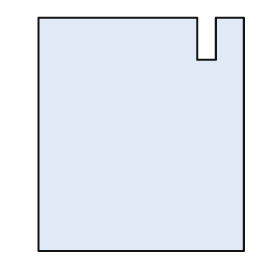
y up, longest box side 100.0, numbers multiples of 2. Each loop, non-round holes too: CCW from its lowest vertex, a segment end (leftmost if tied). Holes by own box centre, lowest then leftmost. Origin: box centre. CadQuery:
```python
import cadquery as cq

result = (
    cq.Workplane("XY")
    .moveTo(-44.0, -50.0)
    .lineTo(44.0, -50.0)
    .lineTo(44.0, 50.0)
    .lineTo(32.0, 50.0)
    .lineTo(32.0, 32.0)
    .lineTo(24.0, 32.0)
    .lineTo(24.0, 50.0)
    .lineTo(-44.0, 50.0)
    .close()
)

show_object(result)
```